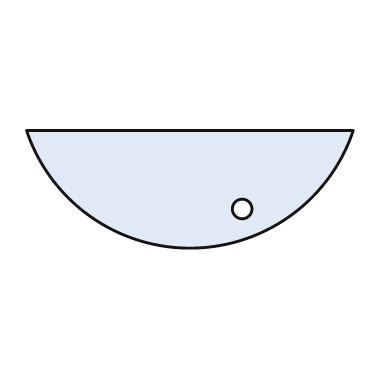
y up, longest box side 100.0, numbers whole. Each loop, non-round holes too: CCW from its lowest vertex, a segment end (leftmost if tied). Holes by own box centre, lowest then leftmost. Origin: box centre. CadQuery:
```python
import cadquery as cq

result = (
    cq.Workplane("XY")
    .moveTo(-50.0, 18.0)
    .threePointArc((0.0, -18.0), (50.0, 18.0))
    .close()
    .moveTo(16.0, -6.0)
    .circle(3.0)
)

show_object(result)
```